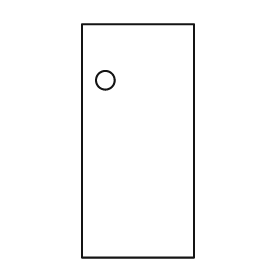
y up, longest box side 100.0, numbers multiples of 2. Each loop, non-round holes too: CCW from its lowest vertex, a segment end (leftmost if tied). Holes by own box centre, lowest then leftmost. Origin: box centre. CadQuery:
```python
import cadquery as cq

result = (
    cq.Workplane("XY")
    .moveTo(-24.0, -50.0)
    .lineTo(24.0, -50.0)
    .lineTo(24.0, 50.0)
    .lineTo(-24.0, 50.0)
    .close()
    .moveTo(-14.0, 26.0)
    .circle(4.0)
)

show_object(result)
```